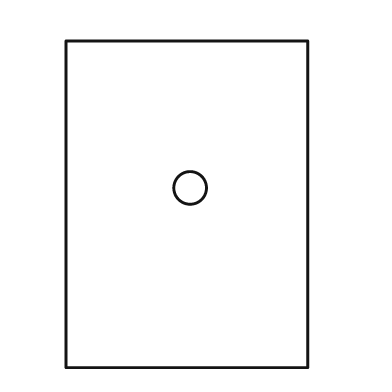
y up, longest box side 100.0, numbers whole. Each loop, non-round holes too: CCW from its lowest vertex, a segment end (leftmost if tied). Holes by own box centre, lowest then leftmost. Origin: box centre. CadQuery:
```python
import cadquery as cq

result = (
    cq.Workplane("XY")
    .moveTo(-37.0, -50.0)
    .lineTo(37.0, -50.0)
    .lineTo(37.0, 50.0)
    .lineTo(-37.0, 50.0)
    .close()
    .moveTo(1.0, 5.0)
    .circle(5.0)
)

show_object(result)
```